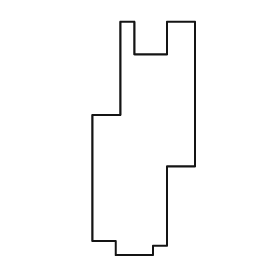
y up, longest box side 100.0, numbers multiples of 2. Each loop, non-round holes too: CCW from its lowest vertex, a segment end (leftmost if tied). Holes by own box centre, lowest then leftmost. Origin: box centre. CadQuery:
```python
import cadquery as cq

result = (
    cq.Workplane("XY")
    .moveTo(-12.0, -50.0)
    .lineTo(4.0, -50.0)
    .lineTo(4.0, -46.0)
    .lineTo(10.0, -46.0)
    .lineTo(10.0, -12.0)
    .lineTo(22.0, -12.0)
    .lineTo(22.0, 50.0)
    .lineTo(10.0, 50.0)
    .lineTo(10.0, 36.0)
    .lineTo(-4.0, 36.0)
    .lineTo(-4.0, 50.0)
    .lineTo(-10.0, 50.0)
    .lineTo(-10.0, 10.0)
    .lineTo(-22.0, 10.0)
    .lineTo(-22.0, -44.0)
    .lineTo(-12.0, -44.0)
    .close()
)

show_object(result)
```